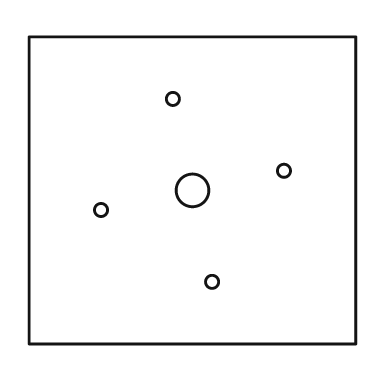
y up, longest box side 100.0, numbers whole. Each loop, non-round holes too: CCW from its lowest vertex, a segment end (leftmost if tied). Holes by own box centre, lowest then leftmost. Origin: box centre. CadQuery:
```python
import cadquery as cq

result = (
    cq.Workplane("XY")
    .moveTo(-50.0, -47.0)
    .lineTo(50.0, -47.0)
    .lineTo(50.0, 47.0)
    .lineTo(-50.0, 47.0)
    .close()
    .moveTo(6.0, -28.0)
    .circle(2.0)
    .moveTo(-28.0, -6.0)
    .circle(2.0)
    .moveTo(0.0, 0.0)
    .circle(5.0)
    .moveTo(28.0, 6.0)
    .circle(2.0)
    .moveTo(-6.0, 28.0)
    .circle(2.0)
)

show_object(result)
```